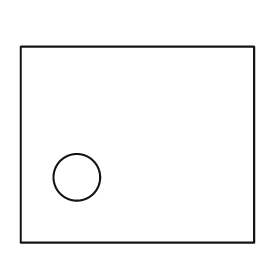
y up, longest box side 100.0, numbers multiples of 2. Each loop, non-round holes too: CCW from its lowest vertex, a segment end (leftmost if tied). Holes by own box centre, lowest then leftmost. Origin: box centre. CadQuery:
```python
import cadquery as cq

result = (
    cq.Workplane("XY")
    .moveTo(-50.0, -42.0)
    .lineTo(50.0, -42.0)
    .lineTo(50.0, 42.0)
    .lineTo(-50.0, 42.0)
    .close()
    .moveTo(-26.0, -14.0)
    .circle(10.0)
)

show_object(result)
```